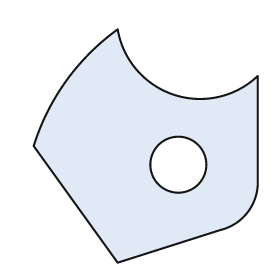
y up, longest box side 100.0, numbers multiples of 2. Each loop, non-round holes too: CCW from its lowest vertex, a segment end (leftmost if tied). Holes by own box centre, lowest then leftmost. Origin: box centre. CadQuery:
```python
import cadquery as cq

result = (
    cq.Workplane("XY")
    .moveTo(-12.0, -50.0)
    .lineTo(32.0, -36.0)
    .threePointArc((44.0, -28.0), (48.0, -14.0))
    .lineTo(48.0, 30.0)
    .threePointArc((12.0, 22.0), (-12.0, 50.0))
    .threePointArc((-34.0, 28.0), (-48.0, 0.0))
    .close()
    .moveTo(14.0, -8.0)
    .circle(12.0)
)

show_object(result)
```